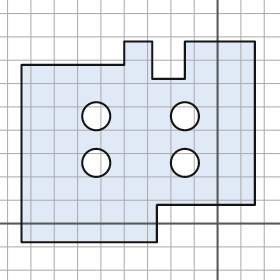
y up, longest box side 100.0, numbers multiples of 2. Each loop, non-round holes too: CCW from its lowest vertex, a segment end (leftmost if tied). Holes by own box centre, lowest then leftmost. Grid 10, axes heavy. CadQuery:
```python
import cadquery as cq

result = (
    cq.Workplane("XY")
    .moveTo(-84.0, -8.0)
    .lineTo(-26.0, -8.0)
    .lineTo(-26.0, 8.0)
    .lineTo(16.0, 8.0)
    .lineTo(16.0, 78.0)
    .lineTo(-14.0, 78.0)
    .lineTo(-14.0, 62.0)
    .lineTo(-28.0, 62.0)
    .lineTo(-28.0, 78.0)
    .lineTo(-40.0, 78.0)
    .lineTo(-40.0, 68.0)
    .lineTo(-84.0, 68.0)
    .close()
    .moveTo(-52.0, 26.0)
    .circle(6.0)
    .moveTo(-14.0, 26.0)
    .circle(6.0)
    .moveTo(-52.0, 46.0)
    .circle(6.0)
    .moveTo(-14.0, 46.0)
    .circle(6.0)
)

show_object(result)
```